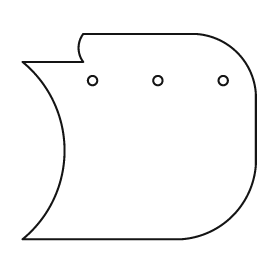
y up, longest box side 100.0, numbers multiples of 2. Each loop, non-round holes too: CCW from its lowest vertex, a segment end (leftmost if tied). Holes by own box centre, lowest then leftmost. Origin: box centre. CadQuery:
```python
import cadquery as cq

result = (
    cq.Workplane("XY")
    .moveTo(-50.0, -44.0)
    .lineTo(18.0, -44.0)
    .threePointArc((40.0, -34.0), (50.0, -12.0))
    .lineTo(50.0, 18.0)
    .threePointArc((42.0, 36.0), (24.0, 44.0))
    .lineTo(-24.0, 44.0)
    .threePointArc((-26.0, 38.0), (-24.0, 32.0))
    .lineTo(-50.0, 32.0)
    .threePointArc((-32.0, -6.0), (-50.0, -44.0))
    .close()
    .moveTo(-20.0, 24.0)
    .circle(2.0)
    .moveTo(8.0, 24.0)
    .circle(2.0)
    .moveTo(36.0, 24.0)
    .circle(2.0)
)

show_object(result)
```